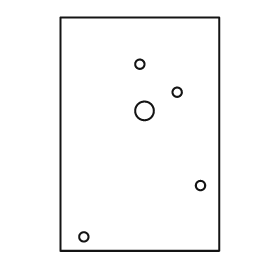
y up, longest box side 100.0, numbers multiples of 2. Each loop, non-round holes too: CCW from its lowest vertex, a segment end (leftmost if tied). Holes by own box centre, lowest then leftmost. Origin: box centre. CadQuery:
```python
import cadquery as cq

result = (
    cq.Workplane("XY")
    .moveTo(-34.0, -50.0)
    .lineTo(34.0, -50.0)
    .lineTo(34.0, 50.0)
    .lineTo(-34.0, 50.0)
    .close()
    .moveTo(-24.0, -44.0)
    .circle(2.0)
    .moveTo(26.0, -22.0)
    .circle(2.0)
    .moveTo(2.0, 10.0)
    .circle(4.0)
    .moveTo(16.0, 18.0)
    .circle(2.0)
    .moveTo(0.0, 30.0)
    .circle(2.0)
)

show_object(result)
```